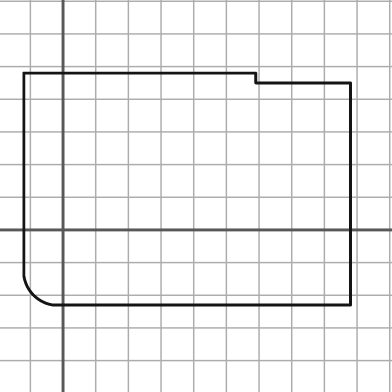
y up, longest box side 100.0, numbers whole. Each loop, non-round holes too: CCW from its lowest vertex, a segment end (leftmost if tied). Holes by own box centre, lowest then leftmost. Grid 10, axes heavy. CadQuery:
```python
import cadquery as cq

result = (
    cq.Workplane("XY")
    .moveTo(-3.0, -23.0)
    .lineTo(88.0, -23.0)
    .lineTo(88.0, 45.0)
    .lineTo(59.0, 45.0)
    .lineTo(59.0, 48.0)
    .lineTo(-12.0, 48.0)
    .lineTo(-12.0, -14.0)
    .threePointArc((-9.0, -20.0), (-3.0, -23.0))
    .close()
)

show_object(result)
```